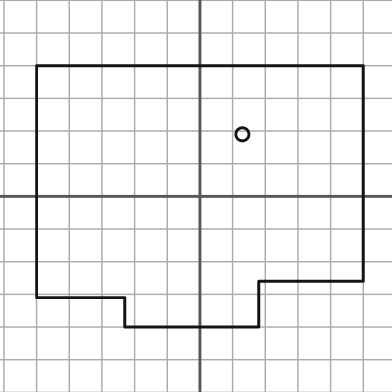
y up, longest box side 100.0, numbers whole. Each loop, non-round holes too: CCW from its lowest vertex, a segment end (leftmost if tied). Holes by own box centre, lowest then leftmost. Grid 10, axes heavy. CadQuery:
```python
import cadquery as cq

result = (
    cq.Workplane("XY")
    .moveTo(-23.0, -40.0)
    .lineTo(18.0, -40.0)
    .lineTo(18.0, -26.0)
    .lineTo(50.0, -26.0)
    .lineTo(50.0, 40.0)
    .lineTo(-50.0, 40.0)
    .lineTo(-50.0, -31.0)
    .lineTo(-23.0, -31.0)
    .close()
    .moveTo(13.0, 19.0)
    .circle(2.0)
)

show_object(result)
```